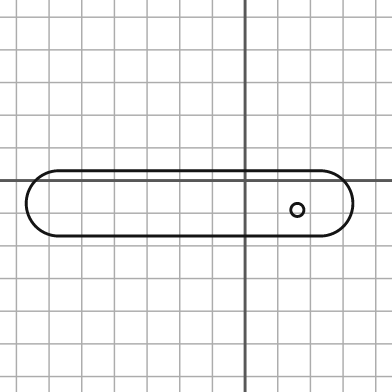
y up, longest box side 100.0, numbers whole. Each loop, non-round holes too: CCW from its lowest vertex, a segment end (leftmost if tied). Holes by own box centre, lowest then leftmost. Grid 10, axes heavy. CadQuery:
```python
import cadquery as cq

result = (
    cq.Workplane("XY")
    .moveTo(-57.0, -17.0)
    .lineTo(23.0, -17.0)
    .threePointArc((33.0, -7.0), (23.0, 3.0))
    .lineTo(-57.0, 3.0)
    .threePointArc((-67.0, -7.0), (-57.0, -17.0))
    .close()
    .moveTo(16.0, -9.0)
    .circle(2.0)
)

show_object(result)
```